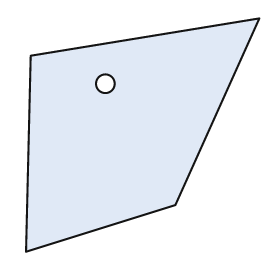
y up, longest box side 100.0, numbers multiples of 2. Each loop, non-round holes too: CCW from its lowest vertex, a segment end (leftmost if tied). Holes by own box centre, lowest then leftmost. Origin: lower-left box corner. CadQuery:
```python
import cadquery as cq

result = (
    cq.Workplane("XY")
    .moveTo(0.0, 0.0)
    .lineTo(64.0, 20.0)
    .lineTo(100.0, 100.0)
    .lineTo(2.0, 84.0)
    .close()
    .moveTo(34.0, 72.0)
    .circle(4.0)
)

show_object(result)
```